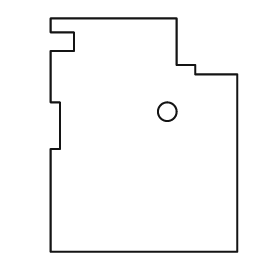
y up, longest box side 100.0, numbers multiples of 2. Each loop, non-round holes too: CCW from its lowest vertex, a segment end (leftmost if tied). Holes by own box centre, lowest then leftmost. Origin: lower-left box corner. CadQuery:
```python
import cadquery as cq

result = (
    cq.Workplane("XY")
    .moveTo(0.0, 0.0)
    .lineTo(80.0, 0.0)
    .lineTo(80.0, 76.0)
    .lineTo(62.0, 76.0)
    .lineTo(62.0, 80.0)
    .lineTo(54.0, 80.0)
    .lineTo(54.0, 100.0)
    .lineTo(0.0, 100.0)
    .lineTo(0.0, 94.0)
    .lineTo(10.0, 94.0)
    .lineTo(10.0, 86.0)
    .lineTo(0.0, 86.0)
    .lineTo(0.0, 64.0)
    .lineTo(4.0, 64.0)
    .lineTo(4.0, 44.0)
    .lineTo(0.0, 44.0)
    .close()
    .moveTo(50.0, 60.0)
    .circle(4.0)
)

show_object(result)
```